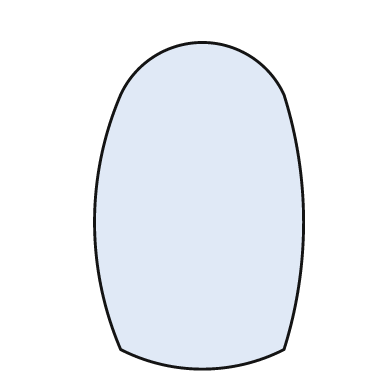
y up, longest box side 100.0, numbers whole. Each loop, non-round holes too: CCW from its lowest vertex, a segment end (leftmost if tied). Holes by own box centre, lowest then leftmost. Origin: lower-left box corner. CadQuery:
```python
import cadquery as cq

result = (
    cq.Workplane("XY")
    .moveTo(8.0, 6.0)
    .threePointArc((33.0, 0.0), (58.0, 6.0))
    .threePointArc((64.0, 45.0), (58.0, 84.0))
    .threePointArc((33.0, 100.0), (8.0, 84.0))
    .threePointArc((0.0, 45.0), (8.0, 6.0))
    .close()
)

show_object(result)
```